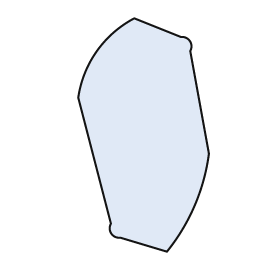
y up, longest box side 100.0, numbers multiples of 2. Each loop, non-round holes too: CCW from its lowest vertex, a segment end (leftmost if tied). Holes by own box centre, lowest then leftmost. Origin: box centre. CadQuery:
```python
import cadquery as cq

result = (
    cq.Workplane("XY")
    .moveTo(10.0, -50.0)
    .threePointArc((22.0, -30.0), (28.0, -8.0))
    .lineTo(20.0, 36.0)
    .threePointArc((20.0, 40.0), (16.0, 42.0))
    .lineTo(-4.0, 50.0)
    .threePointArc((-20.0, 36.0), (-28.0, 16.0))
    .lineTo(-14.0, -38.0)
    .threePointArc((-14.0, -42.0), (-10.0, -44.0))
    .close()
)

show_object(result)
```